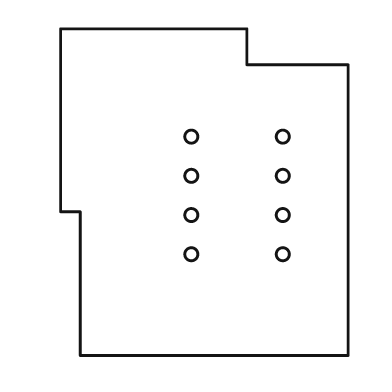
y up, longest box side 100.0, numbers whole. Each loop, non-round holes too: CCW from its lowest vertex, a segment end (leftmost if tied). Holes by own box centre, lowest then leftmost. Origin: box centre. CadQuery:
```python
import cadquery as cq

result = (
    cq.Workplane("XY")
    .moveTo(-38.0, -50.0)
    .lineTo(44.0, -50.0)
    .lineTo(44.0, 39.0)
    .lineTo(13.0, 39.0)
    .lineTo(13.0, 50.0)
    .lineTo(-44.0, 50.0)
    .lineTo(-44.0, -6.0)
    .lineTo(-38.0, -6.0)
    .close()
    .moveTo(-4.0, -19.0)
    .circle(2.0)
    .moveTo(24.0, -19.0)
    .circle(2.0)
    .moveTo(-4.0, -7.0)
    .circle(2.0)
    .moveTo(24.0, -7.0)
    .circle(2.0)
    .moveTo(-4.0, 5.0)
    .circle(2.0)
    .moveTo(24.0, 5.0)
    .circle(2.0)
    .moveTo(-4.0, 17.0)
    .circle(2.0)
    .moveTo(24.0, 17.0)
    .circle(2.0)
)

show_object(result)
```